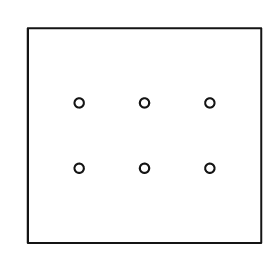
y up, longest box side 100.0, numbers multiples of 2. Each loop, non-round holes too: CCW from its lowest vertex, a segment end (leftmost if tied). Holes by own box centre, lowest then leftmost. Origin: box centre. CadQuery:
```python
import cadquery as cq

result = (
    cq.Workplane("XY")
    .moveTo(-50.0, -46.0)
    .lineTo(50.0, -46.0)
    .lineTo(50.0, 46.0)
    .lineTo(-50.0, 46.0)
    .close()
    .moveTo(-28.0, -14.0)
    .circle(2.0)
    .moveTo(0.0, -14.0)
    .circle(2.0)
    .moveTo(28.0, -14.0)
    .circle(2.0)
    .moveTo(-28.0, 14.0)
    .circle(2.0)
    .moveTo(0.0, 14.0)
    .circle(2.0)
    .moveTo(28.0, 14.0)
    .circle(2.0)
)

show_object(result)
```